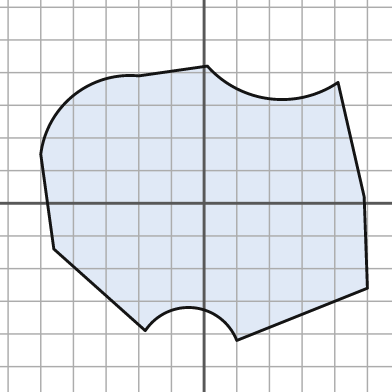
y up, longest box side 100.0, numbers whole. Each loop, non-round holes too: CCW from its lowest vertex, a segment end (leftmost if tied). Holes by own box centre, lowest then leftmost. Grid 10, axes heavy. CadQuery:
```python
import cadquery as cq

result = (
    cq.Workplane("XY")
    .moveTo(10.0, -42.0)
    .lineTo(50.0, -26.0)
    .lineTo(49.0, 2.0)
    .lineTo(41.0, 37.0)
    .threePointArc((20.0, 32.0), (1.0, 42.0))
    .lineTo(-20.0, 39.0)
    .threePointArc((-40.0, 33.0), (-50.0, 15.0))
    .lineTo(-46.0, -14.0)
    .lineTo(-18.0, -39.0)
    .threePointArc((-3.0, -32.0), (10.0, -42.0))
    .close()
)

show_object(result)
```